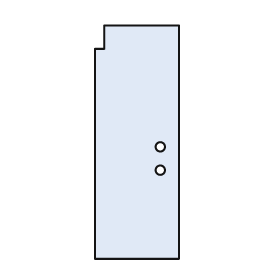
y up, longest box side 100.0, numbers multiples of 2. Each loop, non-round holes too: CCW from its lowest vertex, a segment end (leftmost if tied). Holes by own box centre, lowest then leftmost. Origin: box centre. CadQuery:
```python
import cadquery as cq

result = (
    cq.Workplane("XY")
    .moveTo(-18.0, -50.0)
    .lineTo(18.0, -50.0)
    .lineTo(18.0, 50.0)
    .lineTo(-14.0, 50.0)
    .lineTo(-14.0, 40.0)
    .lineTo(-18.0, 40.0)
    .close()
    .moveTo(10.0, -12.0)
    .circle(2.0)
    .moveTo(10.0, -2.0)
    .circle(2.0)
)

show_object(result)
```